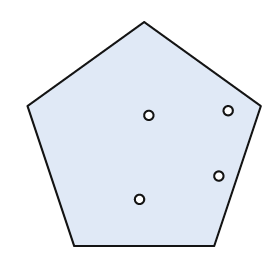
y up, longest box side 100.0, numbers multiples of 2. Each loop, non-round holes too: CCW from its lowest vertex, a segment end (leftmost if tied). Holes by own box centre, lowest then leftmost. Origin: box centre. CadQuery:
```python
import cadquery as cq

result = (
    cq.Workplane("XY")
    .moveTo(-30.0, -48.0)
    .lineTo(30.0, -48.0)
    .lineTo(50.0, 12.0)
    .lineTo(0.0, 48.0)
    .lineTo(-50.0, 12.0)
    .close()
    .moveTo(-2.0, -28.0)
    .circle(2.0)
    .moveTo(32.0, -18.0)
    .circle(2.0)
    .moveTo(2.0, 8.0)
    .circle(2.0)
    .moveTo(36.0, 10.0)
    .circle(2.0)
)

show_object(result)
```